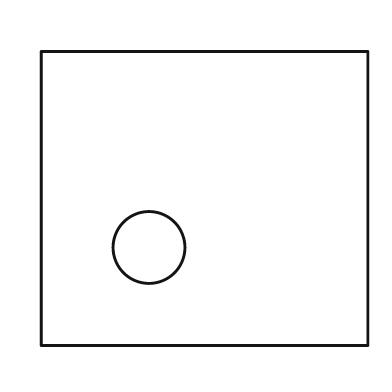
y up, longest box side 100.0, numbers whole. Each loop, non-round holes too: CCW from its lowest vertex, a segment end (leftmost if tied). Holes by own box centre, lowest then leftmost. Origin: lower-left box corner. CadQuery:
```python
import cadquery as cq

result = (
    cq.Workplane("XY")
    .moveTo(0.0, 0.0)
    .lineTo(100.0, 0.0)
    .lineTo(100.0, 90.0)
    .lineTo(0.0, 90.0)
    .close()
    .moveTo(33.0, 30.0)
    .circle(11.0)
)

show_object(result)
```